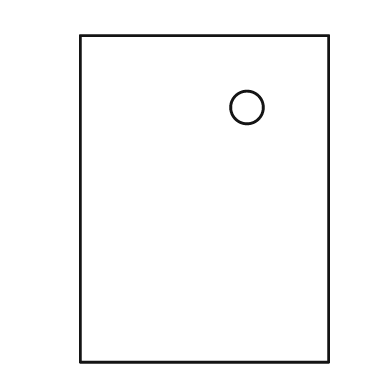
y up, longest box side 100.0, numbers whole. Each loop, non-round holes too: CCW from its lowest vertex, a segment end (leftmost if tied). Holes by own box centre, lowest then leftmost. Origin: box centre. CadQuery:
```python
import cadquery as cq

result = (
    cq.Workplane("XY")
    .moveTo(-38.0, -50.0)
    .lineTo(38.0, -50.0)
    .lineTo(38.0, 50.0)
    .lineTo(-38.0, 50.0)
    .close()
    .moveTo(13.0, 28.0)
    .circle(5.0)
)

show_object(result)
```